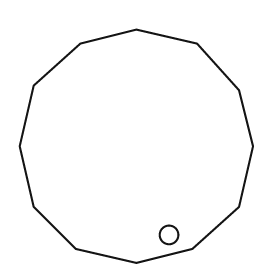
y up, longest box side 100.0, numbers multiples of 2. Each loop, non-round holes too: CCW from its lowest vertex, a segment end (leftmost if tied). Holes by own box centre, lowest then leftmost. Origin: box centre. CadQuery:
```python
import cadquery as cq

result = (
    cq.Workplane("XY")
    .moveTo(0.0, -50.0)
    .lineTo(24.0, -44.0)
    .lineTo(44.0, -26.0)
    .lineTo(50.0, 0.0)
    .lineTo(44.0, 24.0)
    .lineTo(26.0, 44.0)
    .lineTo(0.0, 50.0)
    .lineTo(-24.0, 44.0)
    .lineTo(-44.0, 26.0)
    .lineTo(-50.0, 0.0)
    .lineTo(-44.0, -26.0)
    .lineTo(-26.0, -44.0)
    .close()
    .moveTo(14.0, -38.0)
    .circle(4.0)
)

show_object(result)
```